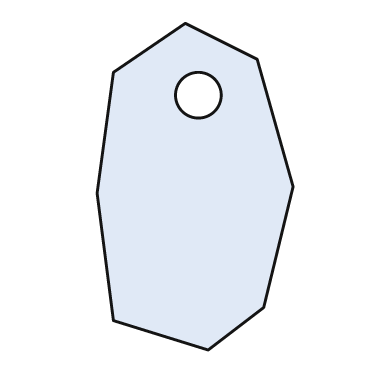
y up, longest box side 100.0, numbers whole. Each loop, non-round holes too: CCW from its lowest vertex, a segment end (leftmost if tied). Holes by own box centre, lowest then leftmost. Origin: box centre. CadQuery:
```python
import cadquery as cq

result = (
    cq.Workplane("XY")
    .moveTo(4.0, -50.0)
    .lineTo(21.0, -37.0)
    .lineTo(30.0, 0.0)
    .lineTo(19.0, 39.0)
    .lineTo(-3.0, 50.0)
    .lineTo(-25.0, 35.0)
    .lineTo(-30.0, -2.0)
    .lineTo(-25.0, -41.0)
    .close()
    .moveTo(1.0, 28.0)
    .circle(7.0)
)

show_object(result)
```